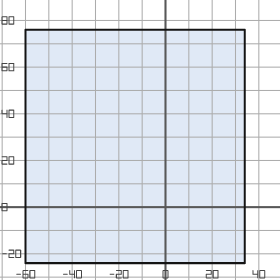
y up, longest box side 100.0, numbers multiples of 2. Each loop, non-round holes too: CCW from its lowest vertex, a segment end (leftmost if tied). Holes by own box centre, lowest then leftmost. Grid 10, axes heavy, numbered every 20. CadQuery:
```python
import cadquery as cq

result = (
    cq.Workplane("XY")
    .moveTo(-60.0, -24.0)
    .lineTo(34.0, -24.0)
    .lineTo(34.0, 76.0)
    .lineTo(-60.0, 76.0)
    .close()
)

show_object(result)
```